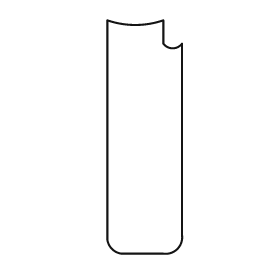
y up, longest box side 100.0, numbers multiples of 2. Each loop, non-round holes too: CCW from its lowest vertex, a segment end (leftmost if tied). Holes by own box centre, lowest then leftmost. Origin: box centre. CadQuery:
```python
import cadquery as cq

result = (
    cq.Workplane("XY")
    .moveTo(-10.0, -50.0)
    .lineTo(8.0, -50.0)
    .threePointArc((14.0, -48.0), (16.0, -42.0))
    .lineTo(16.0, 40.0)
    .threePointArc((12.0, 38.0), (8.0, 40.0))
    .lineTo(8.0, 50.0)
    .threePointArc((-4.0, 48.0), (-16.0, 50.0))
    .lineTo(-16.0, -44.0)
    .threePointArc((-14.0, -48.0), (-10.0, -50.0))
    .close()
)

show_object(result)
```